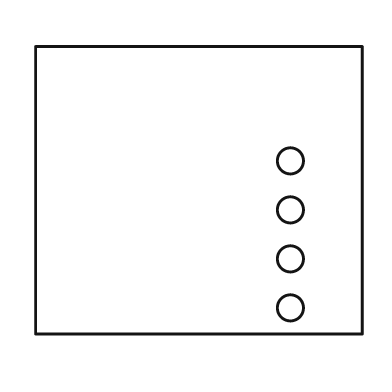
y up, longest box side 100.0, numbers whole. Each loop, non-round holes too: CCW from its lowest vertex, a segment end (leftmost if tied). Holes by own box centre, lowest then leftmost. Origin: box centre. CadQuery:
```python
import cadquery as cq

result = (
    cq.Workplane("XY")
    .moveTo(-50.0, -44.0)
    .lineTo(50.0, -44.0)
    .lineTo(50.0, 44.0)
    .lineTo(-50.0, 44.0)
    .close()
    .moveTo(28.0, -36.0)
    .circle(4.0)
    .moveTo(28.0, -21.0)
    .circle(4.0)
    .moveTo(28.0, -6.0)
    .circle(4.0)
    .moveTo(28.0, 9.0)
    .circle(4.0)
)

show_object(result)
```